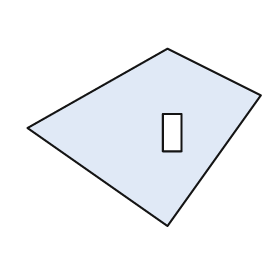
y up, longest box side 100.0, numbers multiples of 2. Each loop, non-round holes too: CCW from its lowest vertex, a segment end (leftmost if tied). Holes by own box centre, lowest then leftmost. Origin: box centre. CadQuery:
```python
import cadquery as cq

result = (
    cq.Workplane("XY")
    .moveTo(10.0, -38.0)
    .lineTo(50.0, 18.0)
    .lineTo(10.0, 38.0)
    .lineTo(-50.0, 4.0)
    .close()
    .moveTo(8.0, -6.0)
    .lineTo(16.0, -6.0)
    .lineTo(16.0, 10.0)
    .lineTo(8.0, 10.0)
    .close()
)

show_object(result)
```